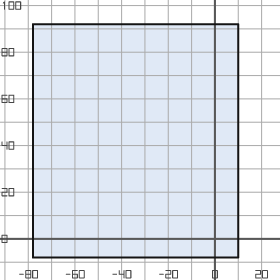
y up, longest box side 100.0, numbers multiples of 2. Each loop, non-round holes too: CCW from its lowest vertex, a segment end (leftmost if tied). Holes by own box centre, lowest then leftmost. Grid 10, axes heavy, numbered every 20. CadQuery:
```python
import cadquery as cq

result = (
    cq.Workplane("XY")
    .moveTo(-78.0, -8.0)
    .lineTo(10.0, -8.0)
    .lineTo(10.0, 92.0)
    .lineTo(-78.0, 92.0)
    .close()
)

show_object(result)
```